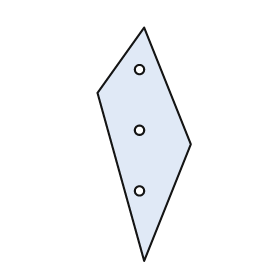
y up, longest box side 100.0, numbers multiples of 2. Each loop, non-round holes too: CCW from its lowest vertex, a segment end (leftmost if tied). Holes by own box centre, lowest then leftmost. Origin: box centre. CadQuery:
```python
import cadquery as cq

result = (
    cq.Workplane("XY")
    .moveTo(0.0, -50.0)
    .lineTo(20.0, 0.0)
    .lineTo(0.0, 50.0)
    .lineTo(-20.0, 22.0)
    .close()
    .moveTo(-2.0, -20.0)
    .circle(2.0)
    .moveTo(-2.0, 6.0)
    .circle(2.0)
    .moveTo(-2.0, 32.0)
    .circle(2.0)
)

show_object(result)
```